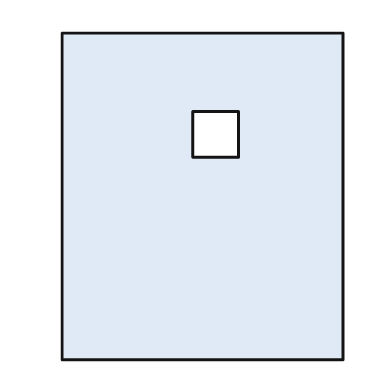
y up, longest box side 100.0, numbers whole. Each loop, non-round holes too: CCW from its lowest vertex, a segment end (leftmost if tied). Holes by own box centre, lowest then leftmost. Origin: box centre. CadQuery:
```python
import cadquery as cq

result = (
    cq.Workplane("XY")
    .moveTo(-43.0, -50.0)
    .lineTo(43.0, -50.0)
    .lineTo(43.0, 50.0)
    .lineTo(-43.0, 50.0)
    .close()
    .moveTo(-3.0, 12.0)
    .lineTo(11.0, 12.0)
    .lineTo(11.0, 26.0)
    .lineTo(-3.0, 26.0)
    .close()
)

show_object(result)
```